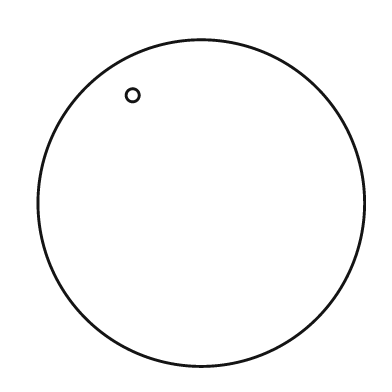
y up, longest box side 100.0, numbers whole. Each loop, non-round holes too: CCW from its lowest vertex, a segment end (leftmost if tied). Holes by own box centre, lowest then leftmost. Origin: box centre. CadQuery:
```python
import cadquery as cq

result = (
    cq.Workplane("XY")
    .moveTo(0.0, 0.0)
    .circle(50.0)
    .moveTo(-21.0, 33.0)
    .circle(2.0)
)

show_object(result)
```